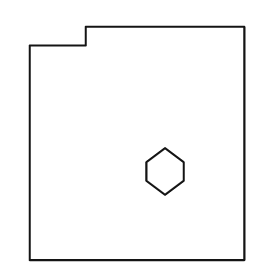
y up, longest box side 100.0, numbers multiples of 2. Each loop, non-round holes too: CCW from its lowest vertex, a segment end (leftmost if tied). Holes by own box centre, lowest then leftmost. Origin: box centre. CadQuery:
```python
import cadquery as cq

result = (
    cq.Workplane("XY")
    .moveTo(-46.0, -50.0)
    .lineTo(46.0, -50.0)
    .lineTo(46.0, 50.0)
    .lineTo(-22.0, 50.0)
    .lineTo(-22.0, 42.0)
    .lineTo(-46.0, 42.0)
    .close()
    .moveTo(12.0, -22.0)
    .lineTo(20.0, -16.0)
    .lineTo(20.0, -8.0)
    .lineTo(12.0, -2.0)
    .lineTo(4.0, -8.0)
    .lineTo(4.0, -16.0)
    .close()
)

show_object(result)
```